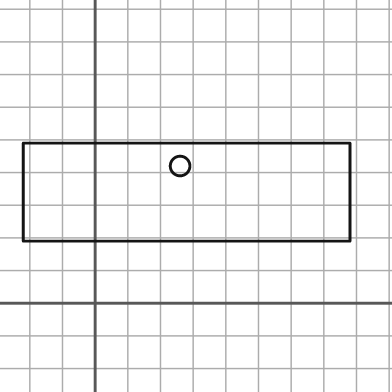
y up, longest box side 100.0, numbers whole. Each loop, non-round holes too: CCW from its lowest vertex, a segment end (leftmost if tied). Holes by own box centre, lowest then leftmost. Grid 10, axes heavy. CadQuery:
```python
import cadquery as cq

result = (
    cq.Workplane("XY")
    .moveTo(-22.0, 19.0)
    .lineTo(78.0, 19.0)
    .lineTo(78.0, 49.0)
    .lineTo(-22.0, 49.0)
    .close()
    .moveTo(26.0, 42.0)
    .circle(3.0)
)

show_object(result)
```